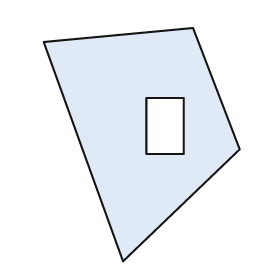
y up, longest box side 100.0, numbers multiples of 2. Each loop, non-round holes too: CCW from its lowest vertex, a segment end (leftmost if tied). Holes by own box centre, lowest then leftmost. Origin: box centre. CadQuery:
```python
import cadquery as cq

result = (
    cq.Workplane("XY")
    .moveTo(-8.0, -50.0)
    .lineTo(42.0, -2.0)
    .lineTo(22.0, 50.0)
    .lineTo(-42.0, 44.0)
    .close()
    .moveTo(2.0, -4.0)
    .lineTo(18.0, -4.0)
    .lineTo(18.0, 20.0)
    .lineTo(2.0, 20.0)
    .close()
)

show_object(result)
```